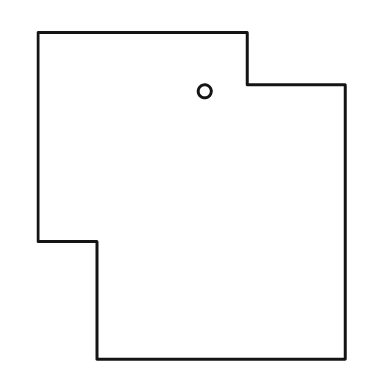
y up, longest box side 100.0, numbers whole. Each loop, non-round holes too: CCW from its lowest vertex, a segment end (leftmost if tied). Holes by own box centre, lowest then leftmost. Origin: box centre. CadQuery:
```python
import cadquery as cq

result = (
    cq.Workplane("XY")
    .moveTo(-29.0, -50.0)
    .lineTo(47.0, -50.0)
    .lineTo(47.0, 34.0)
    .lineTo(17.0, 34.0)
    .lineTo(17.0, 50.0)
    .lineTo(-47.0, 50.0)
    .lineTo(-47.0, -14.0)
    .lineTo(-29.0, -14.0)
    .close()
    .moveTo(4.0, 32.0)
    .circle(2.0)
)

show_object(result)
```